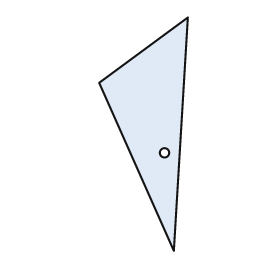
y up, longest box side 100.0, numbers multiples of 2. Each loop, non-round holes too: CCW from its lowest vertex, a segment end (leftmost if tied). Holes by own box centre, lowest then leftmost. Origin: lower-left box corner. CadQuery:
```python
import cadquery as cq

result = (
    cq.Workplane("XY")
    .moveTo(32.0, 0.0)
    .lineTo(38.0, 100.0)
    .lineTo(0.0, 72.0)
    .close()
    .moveTo(28.0, 42.0)
    .circle(2.0)
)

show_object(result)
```